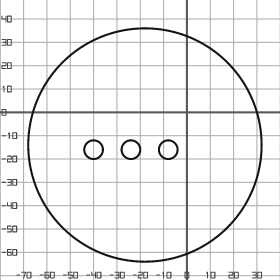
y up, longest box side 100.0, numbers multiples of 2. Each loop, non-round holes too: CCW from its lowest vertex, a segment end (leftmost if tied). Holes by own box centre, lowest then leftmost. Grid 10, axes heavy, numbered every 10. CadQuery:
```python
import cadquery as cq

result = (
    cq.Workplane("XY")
    .moveTo(-18.0, -14.0)
    .circle(50.0)
    .moveTo(-40.0, -16.0)
    .circle(4.0)
    .moveTo(-24.0, -16.0)
    .circle(4.0)
    .moveTo(-8.0, -16.0)
    .circle(4.0)
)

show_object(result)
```